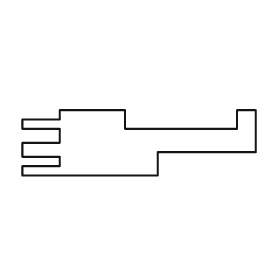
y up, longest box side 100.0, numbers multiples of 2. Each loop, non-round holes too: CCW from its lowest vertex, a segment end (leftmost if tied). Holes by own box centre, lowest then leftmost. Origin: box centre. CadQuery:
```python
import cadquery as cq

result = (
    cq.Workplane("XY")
    .moveTo(-50.0, -14.0)
    .lineTo(8.0, -14.0)
    .lineTo(8.0, -4.0)
    .lineTo(50.0, -4.0)
    .lineTo(50.0, 14.0)
    .lineTo(42.0, 14.0)
    .lineTo(42.0, 6.0)
    .lineTo(-6.0, 6.0)
    .lineTo(-6.0, 14.0)
    .lineTo(-34.0, 14.0)
    .lineTo(-34.0, 10.0)
    .lineTo(-50.0, 10.0)
    .lineTo(-50.0, 6.0)
    .lineTo(-34.0, 6.0)
    .lineTo(-34.0, 0.0)
    .lineTo(-50.0, 0.0)
    .lineTo(-50.0, -6.0)
    .lineTo(-34.0, -6.0)
    .lineTo(-34.0, -10.0)
    .lineTo(-50.0, -10.0)
    .close()
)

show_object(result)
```